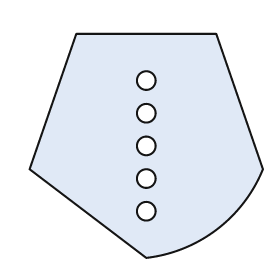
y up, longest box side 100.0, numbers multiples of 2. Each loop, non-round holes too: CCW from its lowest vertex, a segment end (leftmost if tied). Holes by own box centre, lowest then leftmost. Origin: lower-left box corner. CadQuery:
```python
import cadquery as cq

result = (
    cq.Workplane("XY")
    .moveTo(50.0, 0.0)
    .threePointArc((80.0, 12.0), (100.0, 38.0))
    .lineTo(80.0, 96.0)
    .lineTo(20.0, 96.0)
    .lineTo(0.0, 38.0)
    .close()
    .moveTo(50.0, 20.0)
    .circle(4.0)
    .moveTo(50.0, 34.0)
    .circle(4.0)
    .moveTo(50.0, 48.0)
    .circle(4.0)
    .moveTo(50.0, 62.0)
    .circle(4.0)
    .moveTo(50.0, 76.0)
    .circle(4.0)
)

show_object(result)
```